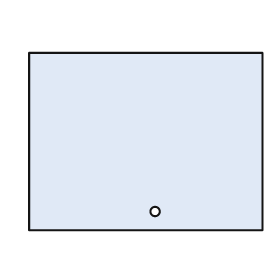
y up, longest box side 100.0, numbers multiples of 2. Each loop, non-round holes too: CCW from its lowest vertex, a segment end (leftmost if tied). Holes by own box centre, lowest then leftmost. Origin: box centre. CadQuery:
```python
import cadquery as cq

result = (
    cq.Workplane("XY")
    .moveTo(-50.0, -38.0)
    .lineTo(50.0, -38.0)
    .lineTo(50.0, 38.0)
    .lineTo(-50.0, 38.0)
    .close()
    .moveTo(4.0, -30.0)
    .circle(2.0)
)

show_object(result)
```